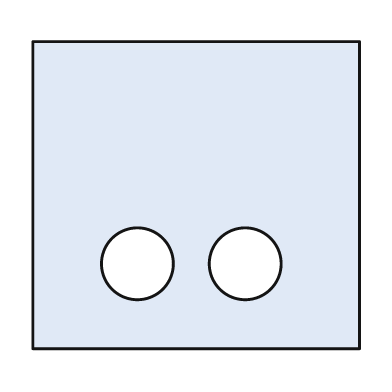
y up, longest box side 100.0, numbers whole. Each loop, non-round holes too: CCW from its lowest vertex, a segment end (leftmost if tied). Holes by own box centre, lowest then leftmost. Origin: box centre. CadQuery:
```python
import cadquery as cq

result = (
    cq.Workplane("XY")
    .moveTo(-50.0, -47.0)
    .lineTo(50.0, -47.0)
    .lineTo(50.0, 47.0)
    .lineTo(-50.0, 47.0)
    .close()
    .moveTo(-18.0, -21.0)
    .circle(11.0)
    .moveTo(15.0, -21.0)
    .circle(11.0)
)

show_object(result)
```